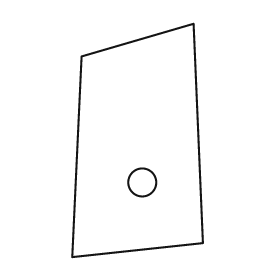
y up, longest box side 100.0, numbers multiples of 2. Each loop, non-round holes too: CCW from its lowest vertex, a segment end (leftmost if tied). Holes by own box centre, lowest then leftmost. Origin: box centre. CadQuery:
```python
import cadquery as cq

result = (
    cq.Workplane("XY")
    .moveTo(-28.0, -50.0)
    .lineTo(28.0, -44.0)
    .lineTo(24.0, 50.0)
    .lineTo(-24.0, 36.0)
    .close()
    .moveTo(2.0, -18.0)
    .circle(6.0)
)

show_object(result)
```